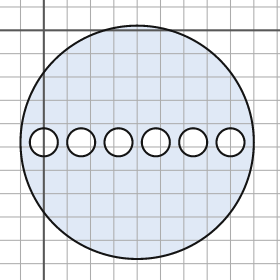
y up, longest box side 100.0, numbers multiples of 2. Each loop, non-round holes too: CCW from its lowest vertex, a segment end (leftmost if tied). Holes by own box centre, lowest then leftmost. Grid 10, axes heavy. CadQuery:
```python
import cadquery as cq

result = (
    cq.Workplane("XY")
    .moveTo(40.0, -48.0)
    .circle(50.0)
    .moveTo(0.0, -48.0)
    .circle(6.0)
    .moveTo(16.0, -48.0)
    .circle(6.0)
    .moveTo(32.0, -48.0)
    .circle(6.0)
    .moveTo(48.0, -48.0)
    .circle(6.0)
    .moveTo(64.0, -48.0)
    .circle(6.0)
    .moveTo(80.0, -48.0)
    .circle(6.0)
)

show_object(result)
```